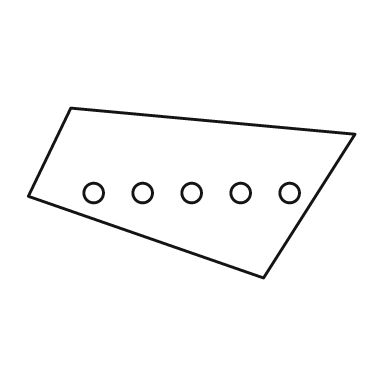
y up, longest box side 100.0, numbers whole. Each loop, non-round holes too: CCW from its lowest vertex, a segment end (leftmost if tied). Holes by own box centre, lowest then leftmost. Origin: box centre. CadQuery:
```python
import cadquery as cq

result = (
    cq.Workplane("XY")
    .moveTo(22.0, -26.0)
    .lineTo(50.0, 18.0)
    .lineTo(-37.0, 26.0)
    .lineTo(-50.0, -1.0)
    .close()
    .moveTo(-30.0, 0.0)
    .circle(3.0)
    .moveTo(-15.0, 0.0)
    .circle(3.0)
    .moveTo(0.0, 0.0)
    .circle(3.0)
    .moveTo(15.0, 0.0)
    .circle(3.0)
    .moveTo(30.0, 0.0)
    .circle(3.0)
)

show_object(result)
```